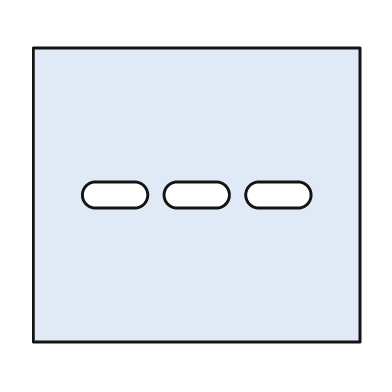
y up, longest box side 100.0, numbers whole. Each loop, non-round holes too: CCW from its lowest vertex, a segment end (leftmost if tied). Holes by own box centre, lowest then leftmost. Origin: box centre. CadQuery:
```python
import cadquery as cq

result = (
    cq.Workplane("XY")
    .moveTo(-50.0, -45.0)
    .lineTo(50.0, -45.0)
    .lineTo(50.0, 45.0)
    .lineTo(-50.0, 45.0)
    .close()
    .moveTo(-31.0, -4.0)
    .lineTo(-19.0, -4.0)
    .threePointArc((-15.0, 0.0), (-19.0, 4.0))
    .lineTo(-31.0, 4.0)
    .threePointArc((-35.0, 0.0), (-31.0, -4.0))
    .close()
    .moveTo(-6.0, -4.0)
    .lineTo(6.0, -4.0)
    .threePointArc((10.0, 0.0), (6.0, 4.0))
    .lineTo(-6.0, 4.0)
    .threePointArc((-10.0, 0.0), (-6.0, -4.0))
    .close()
    .moveTo(19.0, -4.0)
    .lineTo(31.0, -4.0)
    .threePointArc((35.0, 0.0), (31.0, 4.0))
    .lineTo(19.0, 4.0)
    .threePointArc((15.0, 0.0), (19.0, -4.0))
    .close()
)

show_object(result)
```